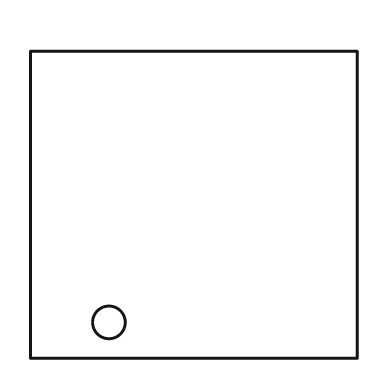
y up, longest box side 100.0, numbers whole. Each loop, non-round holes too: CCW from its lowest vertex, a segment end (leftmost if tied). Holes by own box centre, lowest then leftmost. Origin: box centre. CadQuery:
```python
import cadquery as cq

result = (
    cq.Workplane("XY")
    .moveTo(-50.0, -47.0)
    .lineTo(50.0, -47.0)
    .lineTo(50.0, 47.0)
    .lineTo(-50.0, 47.0)
    .close()
    .moveTo(-26.0, -36.0)
    .circle(5.0)
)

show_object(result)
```